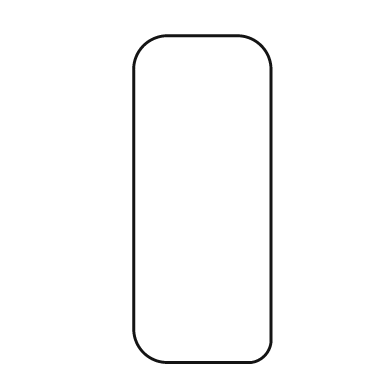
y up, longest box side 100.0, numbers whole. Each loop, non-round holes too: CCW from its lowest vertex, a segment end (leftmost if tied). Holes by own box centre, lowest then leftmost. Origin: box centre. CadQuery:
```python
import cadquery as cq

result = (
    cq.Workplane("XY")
    .moveTo(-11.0, -50.0)
    .lineTo(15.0, -50.0)
    .threePointArc((19.0, -48.0), (21.0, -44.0))
    .lineTo(21.0, 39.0)
    .threePointArc((18.0, 47.0), (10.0, 50.0))
    .lineTo(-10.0, 50.0)
    .threePointArc((-18.0, 47.0), (-21.0, 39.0))
    .lineTo(-21.0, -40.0)
    .threePointArc((-18.0, -47.0), (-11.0, -50.0))
    .close()
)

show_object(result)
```